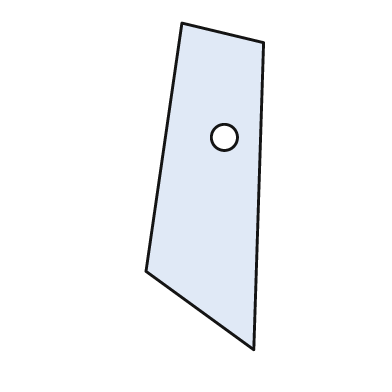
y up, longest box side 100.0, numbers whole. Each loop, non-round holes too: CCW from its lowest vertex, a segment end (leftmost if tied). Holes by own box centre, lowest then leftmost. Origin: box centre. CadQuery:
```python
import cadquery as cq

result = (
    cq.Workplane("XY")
    .moveTo(15.0, -50.0)
    .lineTo(18.0, 44.0)
    .lineTo(-7.0, 50.0)
    .lineTo(-18.0, -26.0)
    .close()
    .moveTo(6.0, 15.0)
    .circle(4.0)
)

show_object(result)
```